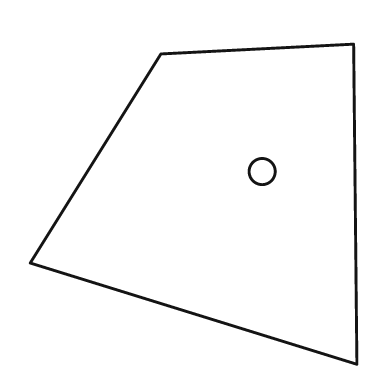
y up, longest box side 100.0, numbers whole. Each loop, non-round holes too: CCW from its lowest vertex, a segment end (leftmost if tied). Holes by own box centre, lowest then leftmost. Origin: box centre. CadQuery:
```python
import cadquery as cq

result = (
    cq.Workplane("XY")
    .moveTo(50.0, -49.0)
    .lineTo(49.0, 49.0)
    .lineTo(-10.0, 46.0)
    .lineTo(-50.0, -18.0)
    .close()
    .moveTo(21.0, 10.0)
    .circle(4.0)
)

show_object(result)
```